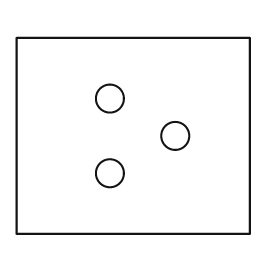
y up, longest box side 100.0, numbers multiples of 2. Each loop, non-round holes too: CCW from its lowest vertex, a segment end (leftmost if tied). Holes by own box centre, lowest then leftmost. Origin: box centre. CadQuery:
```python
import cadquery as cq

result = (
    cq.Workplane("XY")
    .moveTo(-50.0, -42.0)
    .lineTo(50.0, -42.0)
    .lineTo(50.0, 42.0)
    .lineTo(-50.0, 42.0)
    .close()
    .moveTo(-10.0, -16.0)
    .circle(6.0)
    .moveTo(18.0, 0.0)
    .circle(6.0)
    .moveTo(-10.0, 16.0)
    .circle(6.0)
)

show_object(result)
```